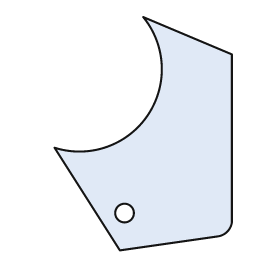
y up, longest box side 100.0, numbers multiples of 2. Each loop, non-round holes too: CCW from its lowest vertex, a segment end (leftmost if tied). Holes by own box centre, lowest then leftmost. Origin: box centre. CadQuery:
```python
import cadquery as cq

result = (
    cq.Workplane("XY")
    .moveTo(-10.0, -50.0)
    .lineTo(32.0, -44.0)
    .threePointArc((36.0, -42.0), (38.0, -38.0))
    .lineTo(38.0, 34.0)
    .lineTo(0.0, 50.0)
    .threePointArc((2.0, 8.0), (-38.0, -6.0))
    .close()
    .moveTo(-8.0, -34.0)
    .circle(4.0)
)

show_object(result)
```